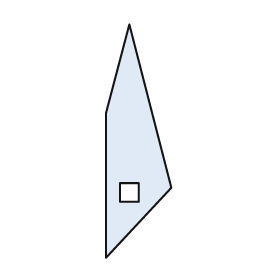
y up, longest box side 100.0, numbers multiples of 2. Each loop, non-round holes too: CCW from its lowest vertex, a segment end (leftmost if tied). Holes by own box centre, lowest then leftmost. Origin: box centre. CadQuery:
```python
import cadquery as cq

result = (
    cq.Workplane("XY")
    .moveTo(-14.0, -50.0)
    .lineTo(14.0, -20.0)
    .lineTo(-4.0, 50.0)
    .lineTo(-14.0, 12.0)
    .close()
    .moveTo(-8.0, -26.0)
    .lineTo(0.0, -26.0)
    .lineTo(0.0, -18.0)
    .lineTo(-8.0, -18.0)
    .close()
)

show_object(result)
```